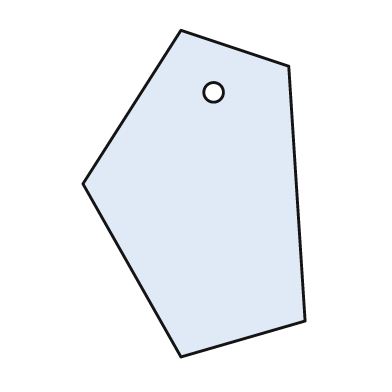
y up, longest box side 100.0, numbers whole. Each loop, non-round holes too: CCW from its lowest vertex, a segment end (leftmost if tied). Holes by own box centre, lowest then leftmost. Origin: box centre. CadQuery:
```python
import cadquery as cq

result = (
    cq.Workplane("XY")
    .moveTo(-4.0, -50.0)
    .lineTo(34.0, -39.0)
    .lineTo(29.0, 39.0)
    .lineTo(-4.0, 50.0)
    .lineTo(-34.0, 3.0)
    .close()
    .moveTo(6.0, 31.0)
    .circle(3.0)
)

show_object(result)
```